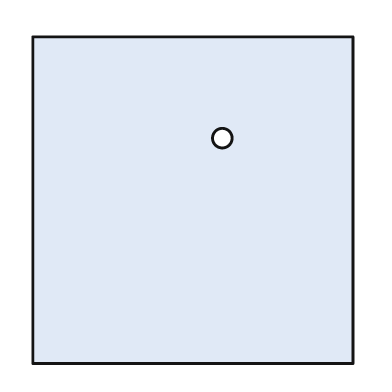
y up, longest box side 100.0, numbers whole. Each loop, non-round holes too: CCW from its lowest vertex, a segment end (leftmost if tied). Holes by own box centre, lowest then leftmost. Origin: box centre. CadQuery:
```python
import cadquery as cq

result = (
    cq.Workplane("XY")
    .moveTo(-49.0, -50.0)
    .lineTo(49.0, -50.0)
    .lineTo(49.0, 50.0)
    .lineTo(-49.0, 50.0)
    .close()
    .moveTo(9.0, 19.0)
    .circle(3.0)
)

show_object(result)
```